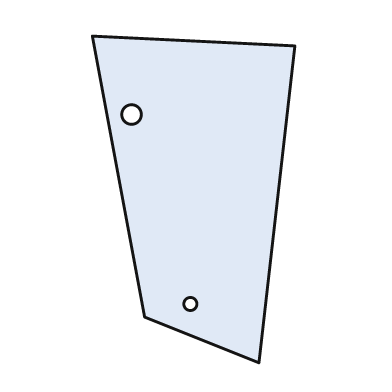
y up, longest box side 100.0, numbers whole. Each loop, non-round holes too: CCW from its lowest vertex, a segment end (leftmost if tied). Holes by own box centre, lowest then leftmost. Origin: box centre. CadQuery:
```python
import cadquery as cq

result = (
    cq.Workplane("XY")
    .moveTo(20.0, -50.0)
    .lineTo(31.0, 47.0)
    .lineTo(-31.0, 50.0)
    .lineTo(-15.0, -36.0)
    .close()
    .moveTo(-1.0, -32.0)
    .circle(2.0)
    .moveTo(-19.0, 26.0)
    .circle(3.0)
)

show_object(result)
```